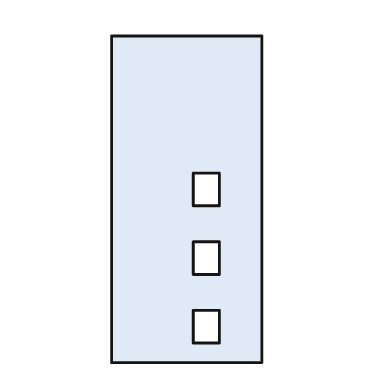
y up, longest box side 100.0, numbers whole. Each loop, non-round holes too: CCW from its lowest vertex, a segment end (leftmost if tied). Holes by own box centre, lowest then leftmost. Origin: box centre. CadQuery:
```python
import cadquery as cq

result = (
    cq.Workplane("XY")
    .moveTo(-23.0, -50.0)
    .lineTo(23.0, -50.0)
    .lineTo(23.0, 50.0)
    .lineTo(-23.0, 50.0)
    .close()
    .moveTo(2.0, -44.0)
    .lineTo(10.0, -44.0)
    .lineTo(10.0, -34.0)
    .lineTo(2.0, -34.0)
    .close()
    .moveTo(2.0, -23.0)
    .lineTo(10.0, -23.0)
    .lineTo(10.0, -13.0)
    .lineTo(2.0, -13.0)
    .close()
    .moveTo(2.0, -2.0)
    .lineTo(10.0, -2.0)
    .lineTo(10.0, 8.0)
    .lineTo(2.0, 8.0)
    .close()
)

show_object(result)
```